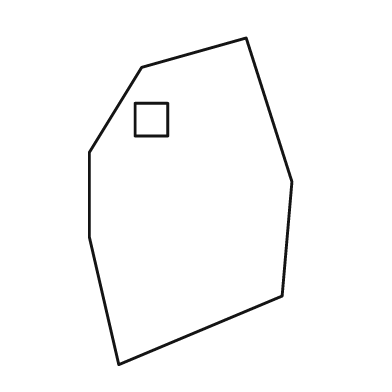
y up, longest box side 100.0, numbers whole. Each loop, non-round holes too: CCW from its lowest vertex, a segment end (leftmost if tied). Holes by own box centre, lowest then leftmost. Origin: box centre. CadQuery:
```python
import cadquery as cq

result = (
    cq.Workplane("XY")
    .moveTo(-22.0, -50.0)
    .lineTo(28.0, -29.0)
    .lineTo(31.0, 6.0)
    .lineTo(17.0, 50.0)
    .lineTo(-15.0, 41.0)
    .lineTo(-31.0, 15.0)
    .lineTo(-31.0, -11.0)
    .close()
    .moveTo(-17.0, 20.0)
    .lineTo(-7.0, 20.0)
    .lineTo(-7.0, 30.0)
    .lineTo(-17.0, 30.0)
    .close()
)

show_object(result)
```